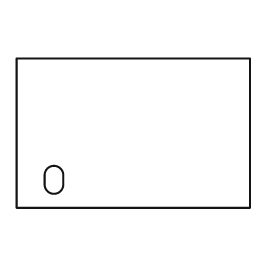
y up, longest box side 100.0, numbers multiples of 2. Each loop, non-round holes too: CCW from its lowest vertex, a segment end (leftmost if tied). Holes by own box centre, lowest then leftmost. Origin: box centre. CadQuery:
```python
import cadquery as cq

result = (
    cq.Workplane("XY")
    .moveTo(-50.0, -32.0)
    .lineTo(50.0, -32.0)
    .lineTo(50.0, 32.0)
    .lineTo(-50.0, 32.0)
    .close()
    .moveTo(-38.0, -22.0)
    .threePointArc((-34.0, -26.0), (-30.0, -22.0))
    .lineTo(-30.0, -18.0)
    .threePointArc((-34.0, -14.0), (-38.0, -18.0))
    .close()
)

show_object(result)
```